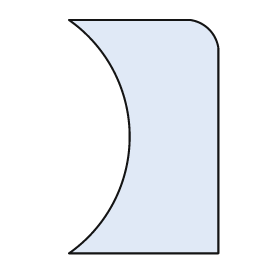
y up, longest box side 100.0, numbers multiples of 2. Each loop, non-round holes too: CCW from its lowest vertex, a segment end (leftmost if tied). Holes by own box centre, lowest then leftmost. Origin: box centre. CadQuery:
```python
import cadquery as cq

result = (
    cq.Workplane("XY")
    .moveTo(-32.0, -50.0)
    .lineTo(32.0, -50.0)
    .lineTo(32.0, 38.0)
    .threePointArc((28.0, 46.0), (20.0, 50.0))
    .lineTo(-32.0, 50.0)
    .threePointArc((-6.0, 0.0), (-32.0, -50.0))
    .close()
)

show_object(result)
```